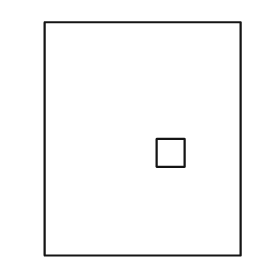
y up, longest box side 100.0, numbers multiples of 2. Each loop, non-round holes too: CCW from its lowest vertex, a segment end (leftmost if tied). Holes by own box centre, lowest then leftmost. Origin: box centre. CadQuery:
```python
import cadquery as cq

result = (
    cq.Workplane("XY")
    .moveTo(-42.0, -50.0)
    .lineTo(42.0, -50.0)
    .lineTo(42.0, 50.0)
    .lineTo(-42.0, 50.0)
    .close()
    .moveTo(6.0, -12.0)
    .lineTo(18.0, -12.0)
    .lineTo(18.0, 0.0)
    .lineTo(6.0, 0.0)
    .close()
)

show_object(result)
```